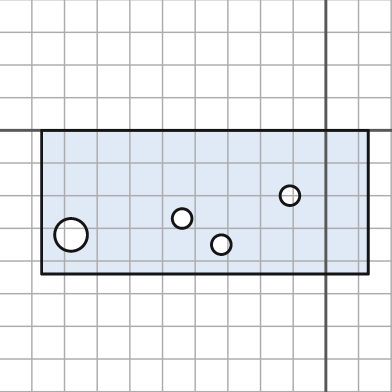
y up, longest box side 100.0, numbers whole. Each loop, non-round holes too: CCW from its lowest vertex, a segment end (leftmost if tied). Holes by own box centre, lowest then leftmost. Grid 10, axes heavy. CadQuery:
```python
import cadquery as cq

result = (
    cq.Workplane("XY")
    .moveTo(-87.0, -44.0)
    .lineTo(13.0, -44.0)
    .lineTo(13.0, 0.0)
    .lineTo(-87.0, 0.0)
    .close()
    .moveTo(-32.0, -35.0)
    .circle(3.0)
    .moveTo(-78.0, -32.0)
    .circle(5.0)
    .moveTo(-44.0, -27.0)
    .circle(3.0)
    .moveTo(-11.0, -20.0)
    .circle(3.0)
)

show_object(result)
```